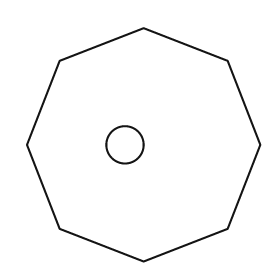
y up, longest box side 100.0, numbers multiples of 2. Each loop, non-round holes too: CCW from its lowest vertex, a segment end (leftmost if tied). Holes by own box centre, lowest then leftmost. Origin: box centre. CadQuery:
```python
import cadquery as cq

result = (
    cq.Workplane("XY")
    .moveTo(0.0, -50.0)
    .lineTo(36.0, -36.0)
    .lineTo(50.0, 0.0)
    .lineTo(36.0, 36.0)
    .lineTo(0.0, 50.0)
    .lineTo(-36.0, 36.0)
    .lineTo(-50.0, 0.0)
    .lineTo(-36.0, -36.0)
    .close()
    .moveTo(-8.0, 0.0)
    .circle(8.0)
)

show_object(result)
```